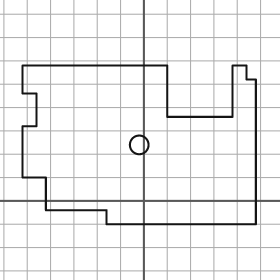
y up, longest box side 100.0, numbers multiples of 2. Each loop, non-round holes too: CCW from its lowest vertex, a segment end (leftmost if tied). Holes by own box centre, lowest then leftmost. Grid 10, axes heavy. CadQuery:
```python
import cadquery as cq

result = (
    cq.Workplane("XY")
    .moveTo(-16.0, -10.0)
    .lineTo(48.0, -10.0)
    .lineTo(48.0, 52.0)
    .lineTo(44.0, 52.0)
    .lineTo(44.0, 58.0)
    .lineTo(38.0, 58.0)
    .lineTo(38.0, 36.0)
    .lineTo(10.0, 36.0)
    .lineTo(10.0, 58.0)
    .lineTo(-52.0, 58.0)
    .lineTo(-52.0, 46.0)
    .lineTo(-46.0, 46.0)
    .lineTo(-46.0, 32.0)
    .lineTo(-52.0, 32.0)
    .lineTo(-52.0, 10.0)
    .lineTo(-42.0, 10.0)
    .lineTo(-42.0, -4.0)
    .lineTo(-16.0, -4.0)
    .close()
    .moveTo(-2.0, 24.0)
    .circle(4.0)
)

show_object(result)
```